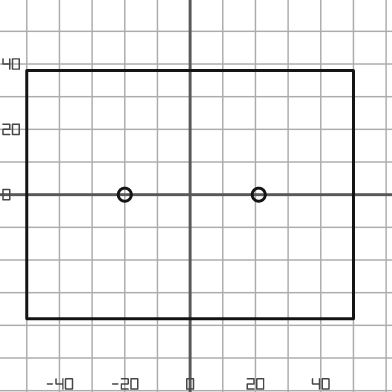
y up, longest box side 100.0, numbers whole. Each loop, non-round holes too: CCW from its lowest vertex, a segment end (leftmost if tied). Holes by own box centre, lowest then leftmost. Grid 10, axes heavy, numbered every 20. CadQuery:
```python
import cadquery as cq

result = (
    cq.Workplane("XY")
    .moveTo(-50.0, -38.0)
    .lineTo(50.0, -38.0)
    .lineTo(50.0, 38.0)
    .lineTo(-50.0, 38.0)
    .close()
    .moveTo(-20.0, 0.0)
    .circle(2.0)
    .moveTo(21.0, 0.0)
    .circle(2.0)
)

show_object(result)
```